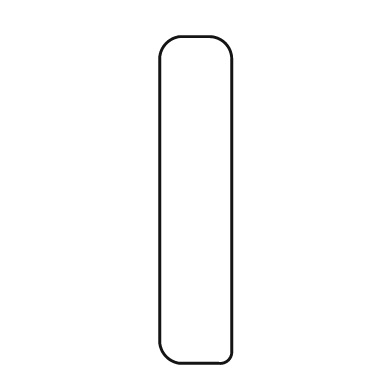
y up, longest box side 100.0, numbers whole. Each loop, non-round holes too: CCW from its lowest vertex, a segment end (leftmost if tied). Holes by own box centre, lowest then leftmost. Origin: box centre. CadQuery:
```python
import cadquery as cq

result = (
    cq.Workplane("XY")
    .moveTo(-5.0, -50.0)
    .lineTo(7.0, -50.0)
    .threePointArc((10.0, -49.0), (11.0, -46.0))
    .lineTo(11.0, 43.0)
    .threePointArc((9.0, 48.0), (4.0, 50.0))
    .lineTo(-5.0, 50.0)
    .threePointArc((-9.0, 48.0), (-11.0, 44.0))
    .lineTo(-11.0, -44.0)
    .threePointArc((-9.0, -48.0), (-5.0, -50.0))
    .close()
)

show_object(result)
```